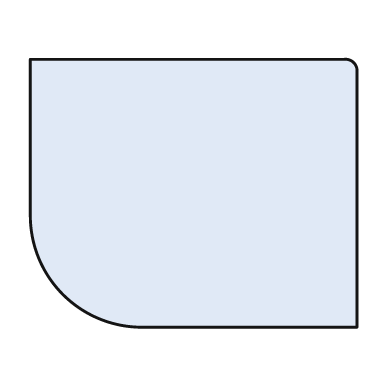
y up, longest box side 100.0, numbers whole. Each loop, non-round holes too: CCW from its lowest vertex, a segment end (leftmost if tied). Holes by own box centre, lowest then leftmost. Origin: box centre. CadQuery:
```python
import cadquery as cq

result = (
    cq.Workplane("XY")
    .moveTo(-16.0, -41.0)
    .lineTo(50.0, -41.0)
    .lineTo(50.0, 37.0)
    .threePointArc((49.0, 40.0), (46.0, 41.0))
    .lineTo(-50.0, 41.0)
    .lineTo(-50.0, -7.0)
    .threePointArc((-40.0, -31.0), (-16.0, -41.0))
    .close()
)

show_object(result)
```